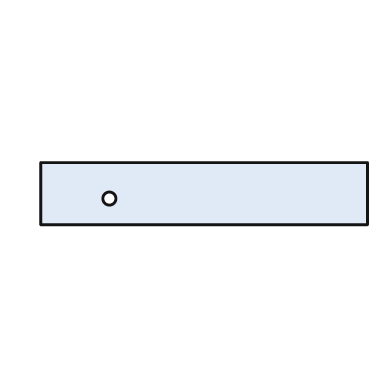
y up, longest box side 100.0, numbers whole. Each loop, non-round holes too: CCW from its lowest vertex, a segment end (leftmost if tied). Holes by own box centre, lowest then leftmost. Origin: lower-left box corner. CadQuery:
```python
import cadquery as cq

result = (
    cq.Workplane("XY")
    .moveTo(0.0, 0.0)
    .lineTo(100.0, 0.0)
    .lineTo(100.0, 19.0)
    .lineTo(0.0, 19.0)
    .close()
    .moveTo(21.0, 8.0)
    .circle(2.0)
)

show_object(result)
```